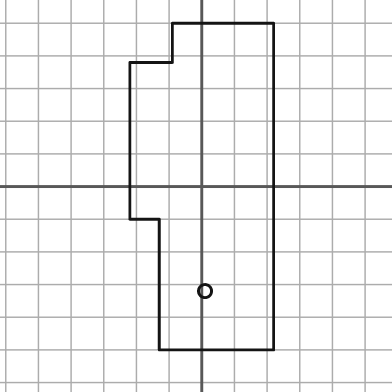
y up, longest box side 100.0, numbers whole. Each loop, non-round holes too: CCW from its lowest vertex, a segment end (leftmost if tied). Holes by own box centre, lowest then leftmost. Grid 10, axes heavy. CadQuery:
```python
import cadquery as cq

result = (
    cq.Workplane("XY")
    .moveTo(-13.0, -50.0)
    .lineTo(22.0, -50.0)
    .lineTo(22.0, 50.0)
    .lineTo(-9.0, 50.0)
    .lineTo(-9.0, 38.0)
    .lineTo(-22.0, 38.0)
    .lineTo(-22.0, -10.0)
    .lineTo(-13.0, -10.0)
    .close()
    .moveTo(1.0, -32.0)
    .circle(2.0)
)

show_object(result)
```